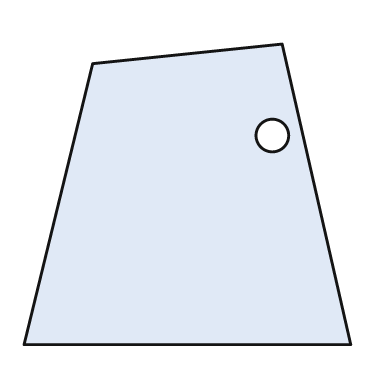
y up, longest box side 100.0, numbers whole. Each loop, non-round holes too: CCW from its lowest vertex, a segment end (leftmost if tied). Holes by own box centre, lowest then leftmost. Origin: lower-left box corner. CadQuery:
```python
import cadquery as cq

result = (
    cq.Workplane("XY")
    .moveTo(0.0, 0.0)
    .lineTo(100.0, 0.0)
    .lineTo(79.0, 92.0)
    .lineTo(21.0, 86.0)
    .close()
    .moveTo(76.0, 64.0)
    .circle(5.0)
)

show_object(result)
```